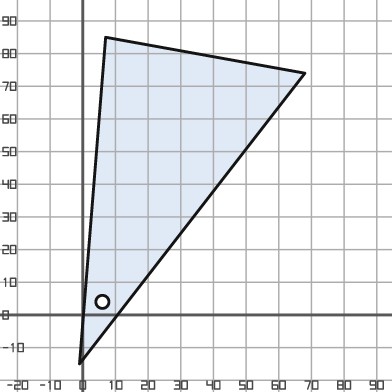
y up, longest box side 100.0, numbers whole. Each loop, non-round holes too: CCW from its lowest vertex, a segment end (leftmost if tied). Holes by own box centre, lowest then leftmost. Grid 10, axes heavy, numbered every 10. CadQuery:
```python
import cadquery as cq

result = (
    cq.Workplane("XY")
    .moveTo(-1.0, -15.0)
    .lineTo(68.0, 74.0)
    .lineTo(7.0, 85.0)
    .close()
    .moveTo(6.0, 4.0)
    .circle(2.0)
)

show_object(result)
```